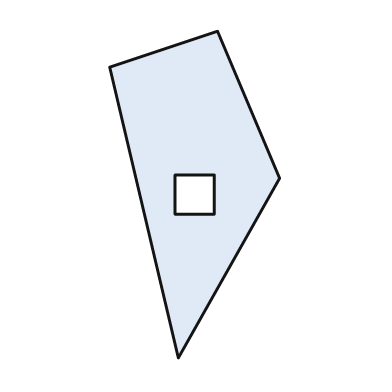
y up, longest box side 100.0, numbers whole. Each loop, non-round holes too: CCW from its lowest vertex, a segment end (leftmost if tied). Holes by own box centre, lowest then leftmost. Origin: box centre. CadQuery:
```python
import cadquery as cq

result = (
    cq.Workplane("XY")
    .moveTo(-5.0, -50.0)
    .lineTo(26.0, 5.0)
    .lineTo(7.0, 50.0)
    .lineTo(-26.0, 39.0)
    .close()
    .moveTo(-6.0, -6.0)
    .lineTo(6.0, -6.0)
    .lineTo(6.0, 6.0)
    .lineTo(-6.0, 6.0)
    .close()
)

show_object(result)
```